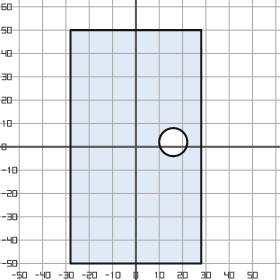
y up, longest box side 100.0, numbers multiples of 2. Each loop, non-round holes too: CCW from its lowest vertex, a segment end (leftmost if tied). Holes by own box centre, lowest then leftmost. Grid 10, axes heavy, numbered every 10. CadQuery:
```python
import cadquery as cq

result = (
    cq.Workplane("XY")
    .moveTo(-28.0, -50.0)
    .lineTo(28.0, -50.0)
    .lineTo(28.0, 50.0)
    .lineTo(-28.0, 50.0)
    .close()
    .moveTo(16.0, 2.0)
    .circle(6.0)
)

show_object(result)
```